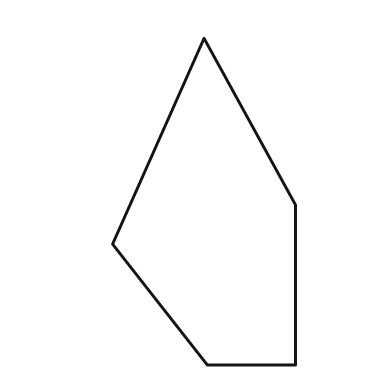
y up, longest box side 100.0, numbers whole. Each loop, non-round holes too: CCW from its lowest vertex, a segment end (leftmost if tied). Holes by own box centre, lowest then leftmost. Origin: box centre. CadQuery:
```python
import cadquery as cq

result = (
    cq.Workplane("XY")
    .moveTo(1.0, -50.0)
    .lineTo(28.0, -50.0)
    .lineTo(28.0, -1.0)
    .lineTo(0.0, 50.0)
    .lineTo(-28.0, -13.0)
    .close()
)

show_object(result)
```